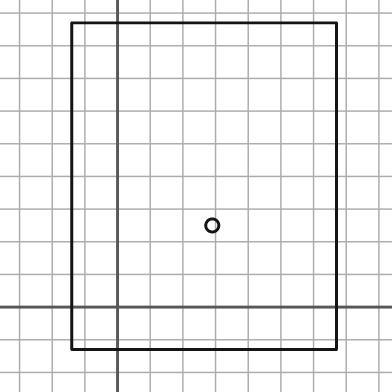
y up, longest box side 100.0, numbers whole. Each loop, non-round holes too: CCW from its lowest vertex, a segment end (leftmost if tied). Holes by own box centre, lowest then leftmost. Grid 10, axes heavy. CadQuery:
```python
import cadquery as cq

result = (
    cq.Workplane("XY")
    .moveTo(-14.0, -13.0)
    .lineTo(67.0, -13.0)
    .lineTo(67.0, 87.0)
    .lineTo(-14.0, 87.0)
    .close()
    .moveTo(29.0, 25.0)
    .circle(2.0)
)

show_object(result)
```